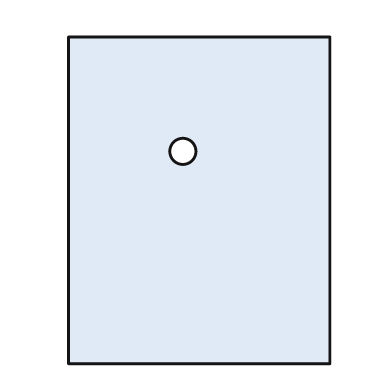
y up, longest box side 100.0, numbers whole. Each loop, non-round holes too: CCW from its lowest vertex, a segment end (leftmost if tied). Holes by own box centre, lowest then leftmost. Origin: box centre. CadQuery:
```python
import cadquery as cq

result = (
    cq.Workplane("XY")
    .moveTo(-40.0, -50.0)
    .lineTo(40.0, -50.0)
    .lineTo(40.0, 50.0)
    .lineTo(-40.0, 50.0)
    .close()
    .moveTo(-5.0, 15.0)
    .circle(4.0)
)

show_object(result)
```